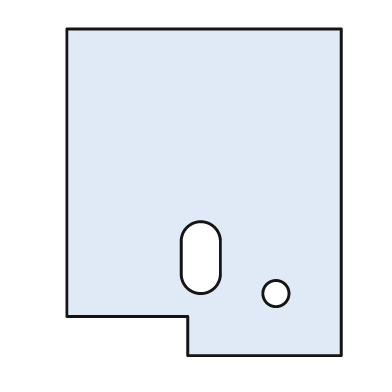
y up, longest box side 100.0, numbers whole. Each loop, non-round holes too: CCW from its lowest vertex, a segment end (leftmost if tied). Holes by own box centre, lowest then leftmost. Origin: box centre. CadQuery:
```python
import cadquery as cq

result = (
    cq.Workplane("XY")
    .moveTo(-5.0, -50.0)
    .lineTo(42.0, -50.0)
    .lineTo(42.0, 50.0)
    .lineTo(-42.0, 50.0)
    .lineTo(-42.0, -38.0)
    .lineTo(-5.0, -38.0)
    .close()
    .moveTo(22.0, -31.0)
    .circle(4.0)
    .moveTo(-7.0, -25.0)
    .threePointArc((-1.0, -31.0), (5.0, -25.0))
    .lineTo(5.0, -15.0)
    .threePointArc((-1.0, -9.0), (-7.0, -15.0))
    .close()
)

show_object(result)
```